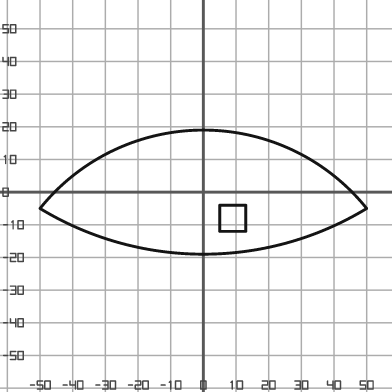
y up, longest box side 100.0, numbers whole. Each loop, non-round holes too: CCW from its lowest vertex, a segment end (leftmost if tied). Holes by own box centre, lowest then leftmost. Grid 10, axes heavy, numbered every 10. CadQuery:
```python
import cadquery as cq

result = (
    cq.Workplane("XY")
    .moveTo(-50.0, -5.0)
    .threePointArc((0.0, -19.0), (50.0, -5.0))
    .threePointArc((0.0, 19.0), (-50.0, -5.0))
    .close()
    .moveTo(5.0, -12.0)
    .lineTo(13.0, -12.0)
    .lineTo(13.0, -4.0)
    .lineTo(5.0, -4.0)
    .close()
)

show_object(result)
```